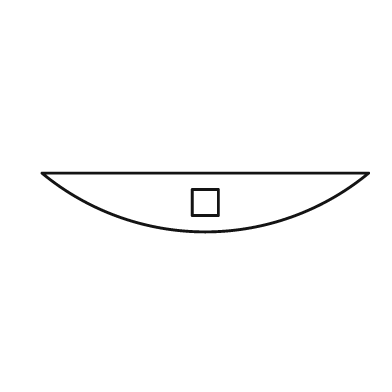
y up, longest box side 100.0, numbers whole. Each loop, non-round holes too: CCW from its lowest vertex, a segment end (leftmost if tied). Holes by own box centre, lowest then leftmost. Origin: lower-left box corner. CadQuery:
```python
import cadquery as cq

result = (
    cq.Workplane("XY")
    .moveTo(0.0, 18.0)
    .threePointArc((50.0, 0.0), (100.0, 18.0))
    .close()
    .moveTo(46.0, 5.0)
    .lineTo(54.0, 5.0)
    .lineTo(54.0, 13.0)
    .lineTo(46.0, 13.0)
    .close()
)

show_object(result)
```